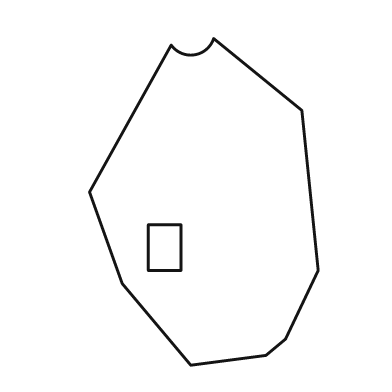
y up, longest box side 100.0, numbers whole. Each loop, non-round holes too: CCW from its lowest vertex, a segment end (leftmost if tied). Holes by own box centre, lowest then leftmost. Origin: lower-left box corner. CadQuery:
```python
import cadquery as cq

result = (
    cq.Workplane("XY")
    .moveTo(31.0, 0.0)
    .lineTo(54.0, 3.0)
    .lineTo(60.0, 8.0)
    .lineTo(70.0, 29.0)
    .lineTo(65.0, 78.0)
    .lineTo(38.0, 100.0)
    .threePointArc((32.0, 95.0), (25.0, 98.0))
    .lineTo(0.0, 53.0)
    .lineTo(10.0, 25.0)
    .close()
    .moveTo(18.0, 29.0)
    .lineTo(28.0, 29.0)
    .lineTo(28.0, 43.0)
    .lineTo(18.0, 43.0)
    .close()
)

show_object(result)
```